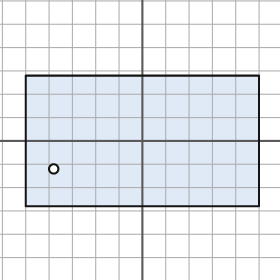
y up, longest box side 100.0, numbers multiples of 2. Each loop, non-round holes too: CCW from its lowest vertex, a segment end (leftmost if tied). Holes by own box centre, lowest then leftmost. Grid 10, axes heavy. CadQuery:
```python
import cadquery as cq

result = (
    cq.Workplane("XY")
    .moveTo(-50.0, -28.0)
    .lineTo(50.0, -28.0)
    .lineTo(50.0, 28.0)
    .lineTo(-50.0, 28.0)
    .close()
    .moveTo(-38.0, -12.0)
    .circle(2.0)
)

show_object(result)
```